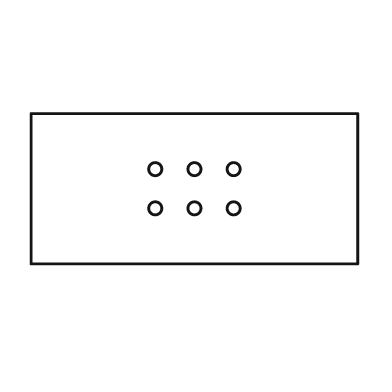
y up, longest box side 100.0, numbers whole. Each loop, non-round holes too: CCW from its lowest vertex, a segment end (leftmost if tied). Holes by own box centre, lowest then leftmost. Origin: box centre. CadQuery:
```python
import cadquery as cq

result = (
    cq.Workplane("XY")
    .moveTo(-50.0, -23.0)
    .lineTo(50.0, -23.0)
    .lineTo(50.0, 23.0)
    .lineTo(-50.0, 23.0)
    .close()
    .moveTo(-12.0, -6.0)
    .circle(2.0)
    .moveTo(0.0, -6.0)
    .circle(2.0)
    .moveTo(12.0, -6.0)
    .circle(2.0)
    .moveTo(-12.0, 6.0)
    .circle(2.0)
    .moveTo(0.0, 6.0)
    .circle(2.0)
    .moveTo(12.0, 6.0)
    .circle(2.0)
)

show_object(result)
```